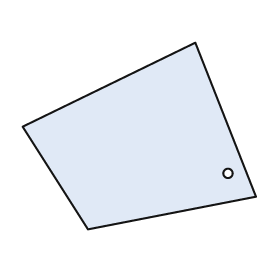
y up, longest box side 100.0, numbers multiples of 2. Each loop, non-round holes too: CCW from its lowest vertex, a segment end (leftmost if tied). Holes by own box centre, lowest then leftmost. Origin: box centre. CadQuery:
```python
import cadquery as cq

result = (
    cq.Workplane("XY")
    .moveTo(-22.0, -40.0)
    .lineTo(50.0, -26.0)
    .lineTo(24.0, 40.0)
    .lineTo(-50.0, 4.0)
    .close()
    .moveTo(38.0, -16.0)
    .circle(2.0)
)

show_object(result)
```